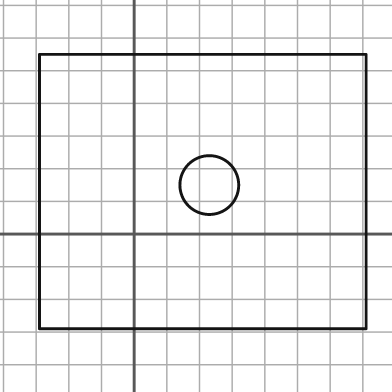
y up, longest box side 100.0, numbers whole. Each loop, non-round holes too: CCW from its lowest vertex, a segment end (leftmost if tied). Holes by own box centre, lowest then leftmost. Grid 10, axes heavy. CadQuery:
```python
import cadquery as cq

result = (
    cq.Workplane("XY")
    .moveTo(-29.0, -29.0)
    .lineTo(71.0, -29.0)
    .lineTo(71.0, 55.0)
    .lineTo(-29.0, 55.0)
    .close()
    .moveTo(23.0, 15.0)
    .circle(9.0)
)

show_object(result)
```